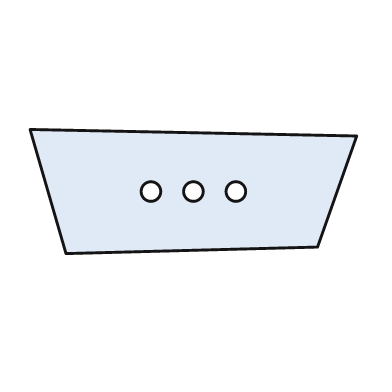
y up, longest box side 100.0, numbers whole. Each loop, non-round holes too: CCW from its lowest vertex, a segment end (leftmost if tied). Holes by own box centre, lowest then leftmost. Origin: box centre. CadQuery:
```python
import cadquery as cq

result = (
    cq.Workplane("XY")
    .moveTo(-39.0, -19.0)
    .lineTo(38.0, -17.0)
    .lineTo(50.0, 17.0)
    .lineTo(-50.0, 19.0)
    .close()
    .moveTo(-13.0, 0.0)
    .circle(3.0)
    .moveTo(0.0, 0.0)
    .circle(3.0)
    .moveTo(13.0, 0.0)
    .circle(3.0)
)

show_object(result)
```